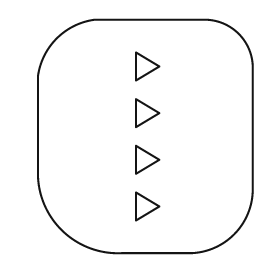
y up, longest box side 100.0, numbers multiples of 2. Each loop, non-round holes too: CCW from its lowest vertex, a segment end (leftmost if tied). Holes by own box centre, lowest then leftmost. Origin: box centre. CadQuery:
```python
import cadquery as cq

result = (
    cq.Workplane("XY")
    .moveTo(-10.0, -50.0)
    .lineTo(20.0, -50.0)
    .threePointArc((38.0, -42.0), (46.0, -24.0))
    .lineTo(46.0, 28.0)
    .threePointArc((40.0, 44.0), (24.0, 50.0))
    .lineTo(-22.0, 50.0)
    .threePointArc((-38.0, 42.0), (-46.0, 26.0))
    .lineTo(-46.0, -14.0)
    .threePointArc((-36.0, -40.0), (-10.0, -50.0))
    .close()
    .moveTo(-4.0, -36.0)
    .lineTo(6.0, -30.0)
    .lineTo(-4.0, -24.0)
    .close()
    .moveTo(-4.0, -16.0)
    .lineTo(6.0, -10.0)
    .lineTo(-4.0, -4.0)
    .close()
    .moveTo(-4.0, 4.0)
    .lineTo(6.0, 10.0)
    .lineTo(-4.0, 16.0)
    .close()
    .moveTo(-4.0, 24.0)
    .lineTo(6.0, 30.0)
    .lineTo(-4.0, 36.0)
    .close()
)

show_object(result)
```